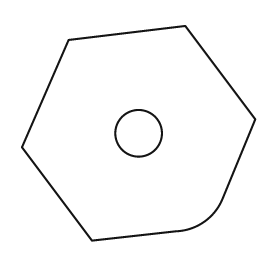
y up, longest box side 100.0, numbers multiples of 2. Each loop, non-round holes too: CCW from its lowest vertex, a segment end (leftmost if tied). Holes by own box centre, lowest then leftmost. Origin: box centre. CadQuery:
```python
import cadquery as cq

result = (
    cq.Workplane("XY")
    .moveTo(-20.0, -46.0)
    .lineTo(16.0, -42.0)
    .threePointArc((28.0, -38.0), (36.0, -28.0))
    .lineTo(50.0, 6.0)
    .lineTo(20.0, 46.0)
    .lineTo(-30.0, 40.0)
    .lineTo(-50.0, -6.0)
    .close()
    .moveTo(0.0, 0.0)
    .circle(10.0)
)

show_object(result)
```